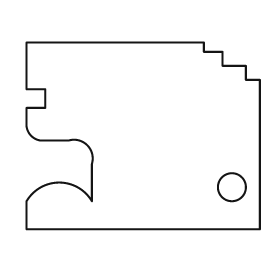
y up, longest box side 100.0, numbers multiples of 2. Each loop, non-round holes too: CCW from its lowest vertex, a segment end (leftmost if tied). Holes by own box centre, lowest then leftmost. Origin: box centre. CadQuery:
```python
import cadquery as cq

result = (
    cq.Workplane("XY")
    .moveTo(-50.0, -40.0)
    .lineTo(50.0, -40.0)
    .lineTo(50.0, 24.0)
    .lineTo(44.0, 24.0)
    .lineTo(44.0, 30.0)
    .lineTo(34.0, 30.0)
    .lineTo(34.0, 36.0)
    .lineTo(26.0, 36.0)
    .lineTo(26.0, 40.0)
    .lineTo(-50.0, 40.0)
    .lineTo(-50.0, 20.0)
    .lineTo(-42.0, 20.0)
    .lineTo(-42.0, 12.0)
    .lineTo(-50.0, 12.0)
    .lineTo(-50.0, 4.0)
    .threePointArc((-48.0, 0.0), (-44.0, -2.0))
    .lineTo(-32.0, -2.0)
    .threePointArc((-24.0, -4.0), (-22.0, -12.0))
    .lineTo(-22.0, -28.0)
    .threePointArc((-36.0, -20.0), (-50.0, -28.0))
    .close()
    .moveTo(38.0, -22.0)
    .circle(6.0)
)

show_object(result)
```